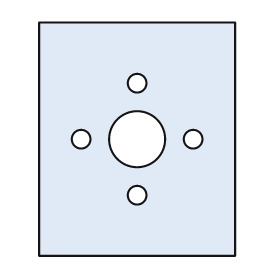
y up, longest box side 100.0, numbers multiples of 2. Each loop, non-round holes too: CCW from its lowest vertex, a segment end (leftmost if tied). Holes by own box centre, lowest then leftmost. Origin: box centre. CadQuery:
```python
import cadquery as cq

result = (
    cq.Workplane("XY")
    .moveTo(-42.0, -50.0)
    .lineTo(42.0, -50.0)
    .lineTo(42.0, 50.0)
    .lineTo(-42.0, 50.0)
    .close()
    .moveTo(0.0, -24.0)
    .circle(4.0)
    .moveTo(-24.0, 0.0)
    .circle(4.0)
    .moveTo(0.0, 0.0)
    .circle(12.0)
    .moveTo(24.0, 0.0)
    .circle(4.0)
    .moveTo(0.0, 24.0)
    .circle(4.0)
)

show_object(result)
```